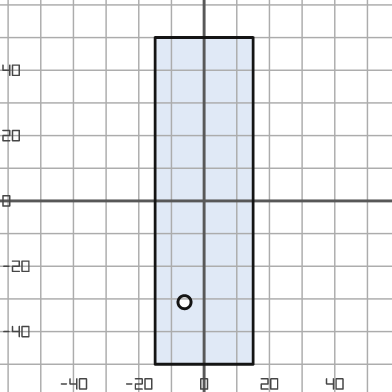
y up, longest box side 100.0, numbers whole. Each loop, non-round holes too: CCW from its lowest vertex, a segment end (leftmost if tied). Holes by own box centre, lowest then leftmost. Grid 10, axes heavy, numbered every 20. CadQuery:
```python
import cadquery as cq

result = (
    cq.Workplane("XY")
    .moveTo(-15.0, -50.0)
    .lineTo(15.0, -50.0)
    .lineTo(15.0, 50.0)
    .lineTo(-15.0, 50.0)
    .close()
    .moveTo(-6.0, -31.0)
    .circle(2.0)
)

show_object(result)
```